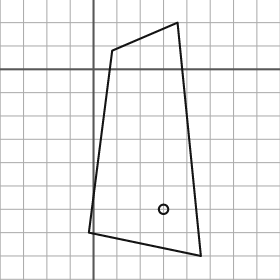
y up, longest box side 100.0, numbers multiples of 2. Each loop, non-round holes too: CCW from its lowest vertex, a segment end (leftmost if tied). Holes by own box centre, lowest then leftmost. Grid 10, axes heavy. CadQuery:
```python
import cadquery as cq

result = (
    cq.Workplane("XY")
    .moveTo(46.0, -80.0)
    .lineTo(36.0, 20.0)
    .lineTo(8.0, 8.0)
    .lineTo(-2.0, -70.0)
    .close()
    .moveTo(30.0, -60.0)
    .circle(2.0)
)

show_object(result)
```